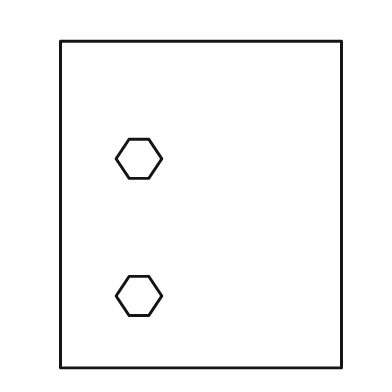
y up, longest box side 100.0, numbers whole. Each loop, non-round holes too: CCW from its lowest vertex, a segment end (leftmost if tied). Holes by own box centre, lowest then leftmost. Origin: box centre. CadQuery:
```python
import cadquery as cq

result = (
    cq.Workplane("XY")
    .moveTo(-43.0, -50.0)
    .lineTo(43.0, -50.0)
    .lineTo(43.0, 50.0)
    .lineTo(-43.0, 50.0)
    .close()
    .moveTo(-22.0, -34.0)
    .lineTo(-16.0, -34.0)
    .lineTo(-12.0, -28.0)
    .lineTo(-16.0, -22.0)
    .lineTo(-22.0, -22.0)
    .lineTo(-26.0, -28.0)
    .close()
    .moveTo(-22.0, 8.0)
    .lineTo(-16.0, 8.0)
    .lineTo(-12.0, 14.0)
    .lineTo(-16.0, 20.0)
    .lineTo(-22.0, 20.0)
    .lineTo(-26.0, 14.0)
    .close()
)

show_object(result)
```